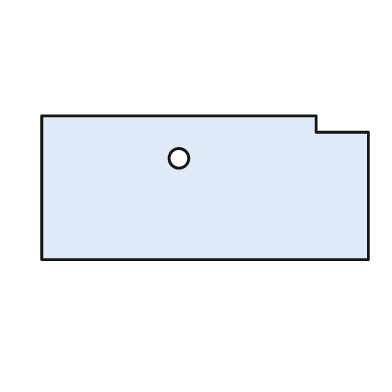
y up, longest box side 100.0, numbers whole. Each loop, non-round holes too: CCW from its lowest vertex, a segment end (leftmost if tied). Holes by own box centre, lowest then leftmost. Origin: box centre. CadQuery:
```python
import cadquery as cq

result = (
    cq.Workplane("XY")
    .moveTo(-50.0, -22.0)
    .lineTo(50.0, -22.0)
    .lineTo(50.0, 17.0)
    .lineTo(34.0, 17.0)
    .lineTo(34.0, 22.0)
    .lineTo(-50.0, 22.0)
    .close()
    .moveTo(-8.0, 9.0)
    .circle(3.0)
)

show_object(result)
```